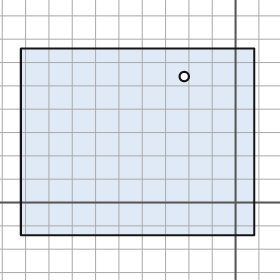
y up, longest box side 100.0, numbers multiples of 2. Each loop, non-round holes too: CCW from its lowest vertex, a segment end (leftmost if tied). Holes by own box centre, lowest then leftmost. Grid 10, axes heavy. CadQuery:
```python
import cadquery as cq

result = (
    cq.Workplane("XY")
    .moveTo(-92.0, -14.0)
    .lineTo(8.0, -14.0)
    .lineTo(8.0, 66.0)
    .lineTo(-92.0, 66.0)
    .close()
    .moveTo(-22.0, 54.0)
    .circle(2.0)
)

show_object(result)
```